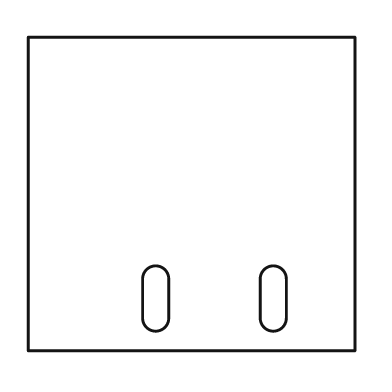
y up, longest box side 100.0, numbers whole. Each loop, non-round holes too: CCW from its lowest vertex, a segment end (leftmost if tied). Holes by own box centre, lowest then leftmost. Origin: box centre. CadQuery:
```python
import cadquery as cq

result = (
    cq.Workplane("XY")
    .moveTo(-50.0, -48.0)
    .lineTo(50.0, -48.0)
    .lineTo(50.0, 48.0)
    .lineTo(-50.0, 48.0)
    .close()
    .moveTo(-15.0, -38.0)
    .threePointArc((-11.0, -42.0), (-7.0, -38.0))
    .lineTo(-7.0, -26.0)
    .threePointArc((-11.0, -22.0), (-15.0, -26.0))
    .close()
    .moveTo(21.0, -38.0)
    .threePointArc((25.0, -42.0), (29.0, -38.0))
    .lineTo(29.0, -26.0)
    .threePointArc((25.0, -22.0), (21.0, -26.0))
    .close()
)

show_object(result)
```